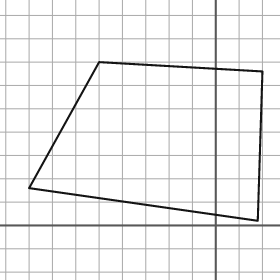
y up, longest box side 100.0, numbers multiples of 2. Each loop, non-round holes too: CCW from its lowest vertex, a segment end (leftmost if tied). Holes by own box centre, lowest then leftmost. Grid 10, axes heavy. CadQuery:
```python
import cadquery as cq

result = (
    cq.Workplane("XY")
    .moveTo(18.0, 2.0)
    .lineTo(20.0, 66.0)
    .lineTo(-50.0, 70.0)
    .lineTo(-80.0, 16.0)
    .close()
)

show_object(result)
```